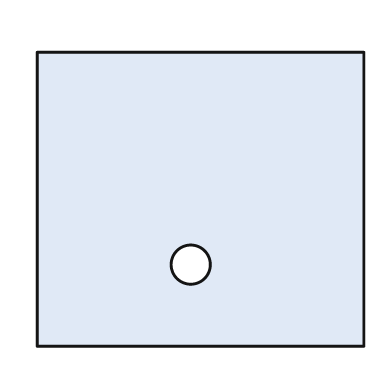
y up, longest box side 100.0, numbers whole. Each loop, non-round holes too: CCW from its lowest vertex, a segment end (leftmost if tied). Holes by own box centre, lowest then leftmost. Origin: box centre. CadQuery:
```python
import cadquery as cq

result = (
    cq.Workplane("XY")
    .moveTo(-50.0, -45.0)
    .lineTo(50.0, -45.0)
    .lineTo(50.0, 45.0)
    .lineTo(-50.0, 45.0)
    .close()
    .moveTo(-3.0, -20.0)
    .circle(6.0)
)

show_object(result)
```